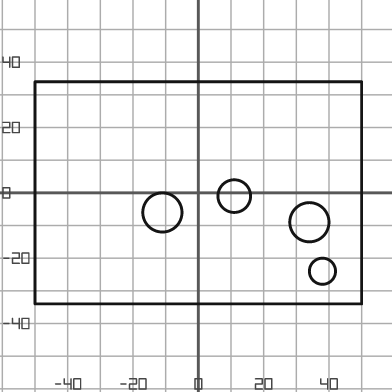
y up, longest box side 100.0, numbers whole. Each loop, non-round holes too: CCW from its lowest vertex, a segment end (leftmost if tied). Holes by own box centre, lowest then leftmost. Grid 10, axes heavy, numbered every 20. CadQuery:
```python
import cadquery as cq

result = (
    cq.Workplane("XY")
    .moveTo(-50.0, -34.0)
    .lineTo(50.0, -34.0)
    .lineTo(50.0, 34.0)
    .lineTo(-50.0, 34.0)
    .close()
    .moveTo(38.0, -24.0)
    .circle(4.0)
    .moveTo(34.0, -9.0)
    .circle(6.0)
    .moveTo(-11.0, -6.0)
    .circle(6.0)
    .moveTo(11.0, -1.0)
    .circle(5.0)
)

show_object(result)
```